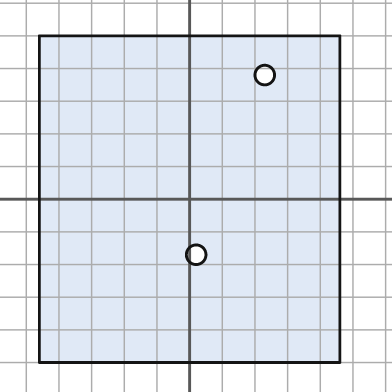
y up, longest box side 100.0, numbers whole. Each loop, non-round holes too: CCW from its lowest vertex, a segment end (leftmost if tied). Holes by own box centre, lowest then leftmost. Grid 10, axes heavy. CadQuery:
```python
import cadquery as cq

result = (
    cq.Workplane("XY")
    .moveTo(-46.0, -50.0)
    .lineTo(46.0, -50.0)
    .lineTo(46.0, 50.0)
    .lineTo(-46.0, 50.0)
    .close()
    .moveTo(2.0, -17.0)
    .circle(3.0)
    .moveTo(23.0, 38.0)
    .circle(3.0)
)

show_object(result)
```